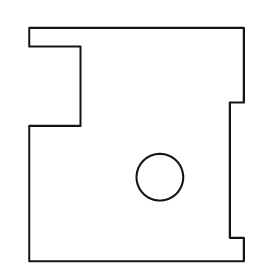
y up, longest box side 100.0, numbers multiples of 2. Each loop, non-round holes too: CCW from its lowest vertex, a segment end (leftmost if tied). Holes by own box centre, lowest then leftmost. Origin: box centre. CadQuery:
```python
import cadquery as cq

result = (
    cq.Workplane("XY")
    .moveTo(-46.0, -50.0)
    .lineTo(46.0, -50.0)
    .lineTo(46.0, -40.0)
    .lineTo(40.0, -40.0)
    .lineTo(40.0, 18.0)
    .lineTo(46.0, 18.0)
    .lineTo(46.0, 50.0)
    .lineTo(-46.0, 50.0)
    .lineTo(-46.0, 42.0)
    .lineTo(-24.0, 42.0)
    .lineTo(-24.0, 8.0)
    .lineTo(-46.0, 8.0)
    .close()
    .moveTo(10.0, -14.0)
    .circle(10.0)
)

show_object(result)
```